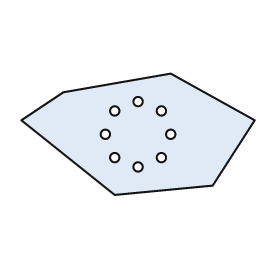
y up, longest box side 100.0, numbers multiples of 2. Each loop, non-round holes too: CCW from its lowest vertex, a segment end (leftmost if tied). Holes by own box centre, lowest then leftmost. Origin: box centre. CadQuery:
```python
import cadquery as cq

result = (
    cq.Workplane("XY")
    .moveTo(-10.0, -26.0)
    .lineTo(32.0, -22.0)
    .lineTo(50.0, 6.0)
    .lineTo(14.0, 26.0)
    .lineTo(-32.0, 18.0)
    .lineTo(-50.0, 6.0)
    .close()
    .moveTo(0.0, -14.0)
    .circle(2.0)
    .moveTo(-10.0, -10.0)
    .circle(2.0)
    .moveTo(10.0, -10.0)
    .circle(2.0)
    .moveTo(-14.0, 0.0)
    .circle(2.0)
    .moveTo(14.0, 0.0)
    .circle(2.0)
    .moveTo(-10.0, 10.0)
    .circle(2.0)
    .moveTo(10.0, 10.0)
    .circle(2.0)
    .moveTo(0.0, 14.0)
    .circle(2.0)
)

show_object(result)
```